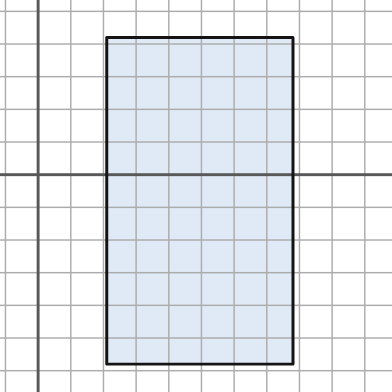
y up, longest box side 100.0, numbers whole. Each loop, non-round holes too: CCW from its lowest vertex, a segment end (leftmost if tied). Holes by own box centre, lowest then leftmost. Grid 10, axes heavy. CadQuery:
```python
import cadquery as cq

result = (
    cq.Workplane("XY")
    .moveTo(21.0, -58.0)
    .lineTo(78.0, -58.0)
    .lineTo(78.0, 42.0)
    .lineTo(21.0, 42.0)
    .close()
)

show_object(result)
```